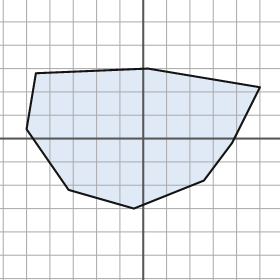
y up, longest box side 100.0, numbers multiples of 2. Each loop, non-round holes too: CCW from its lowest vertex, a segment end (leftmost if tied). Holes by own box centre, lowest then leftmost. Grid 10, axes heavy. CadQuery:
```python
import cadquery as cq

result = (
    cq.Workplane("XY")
    .moveTo(-4.0, -30.0)
    .lineTo(26.0, -18.0)
    .lineTo(38.0, -2.0)
    .lineTo(50.0, 22.0)
    .lineTo(2.0, 30.0)
    .lineTo(-46.0, 28.0)
    .lineTo(-50.0, 4.0)
    .lineTo(-32.0, -22.0)
    .close()
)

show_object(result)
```